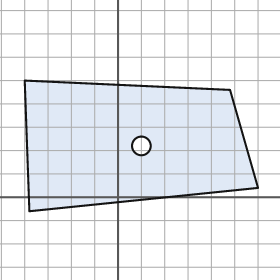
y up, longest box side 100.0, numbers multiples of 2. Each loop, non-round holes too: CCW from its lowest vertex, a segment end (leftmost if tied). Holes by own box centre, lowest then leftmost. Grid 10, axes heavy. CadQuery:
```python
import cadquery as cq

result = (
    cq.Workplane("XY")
    .moveTo(-38.0, -6.0)
    .lineTo(60.0, 4.0)
    .lineTo(48.0, 46.0)
    .lineTo(-40.0, 50.0)
    .close()
    .moveTo(10.0, 22.0)
    .circle(4.0)
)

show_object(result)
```